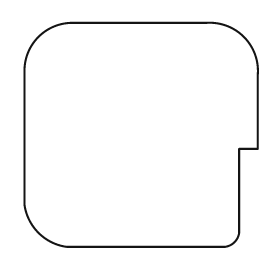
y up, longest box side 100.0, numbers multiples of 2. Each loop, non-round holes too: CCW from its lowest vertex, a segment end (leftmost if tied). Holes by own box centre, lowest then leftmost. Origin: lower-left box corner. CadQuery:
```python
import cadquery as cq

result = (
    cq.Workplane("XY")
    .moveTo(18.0, 0.0)
    .lineTo(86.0, 0.0)
    .threePointArc((90.0, 2.0), (92.0, 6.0))
    .lineTo(92.0, 42.0)
    .lineTo(100.0, 42.0)
    .lineTo(100.0, 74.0)
    .threePointArc((94.0, 90.0), (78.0, 96.0))
    .lineTo(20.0, 96.0)
    .threePointArc((6.0, 90.0), (0.0, 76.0))
    .lineTo(0.0, 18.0)
    .threePointArc((6.0, 6.0), (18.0, 0.0))
    .close()
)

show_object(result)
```